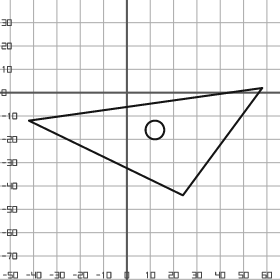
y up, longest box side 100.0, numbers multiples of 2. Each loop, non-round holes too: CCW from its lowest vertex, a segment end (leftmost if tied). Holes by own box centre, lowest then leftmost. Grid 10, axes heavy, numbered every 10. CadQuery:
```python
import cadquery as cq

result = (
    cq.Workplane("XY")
    .moveTo(24.0, -44.0)
    .lineTo(58.0, 2.0)
    .lineTo(-42.0, -12.0)
    .close()
    .moveTo(12.0, -16.0)
    .circle(4.0)
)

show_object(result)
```